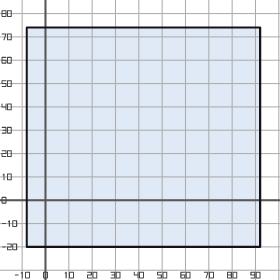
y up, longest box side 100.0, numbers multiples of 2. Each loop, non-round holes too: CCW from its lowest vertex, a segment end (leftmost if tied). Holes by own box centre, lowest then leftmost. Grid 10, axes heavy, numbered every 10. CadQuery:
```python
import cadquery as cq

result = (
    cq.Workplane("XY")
    .moveTo(-8.0, -20.0)
    .lineTo(92.0, -20.0)
    .lineTo(92.0, 74.0)
    .lineTo(-8.0, 74.0)
    .close()
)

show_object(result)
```